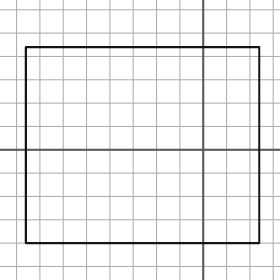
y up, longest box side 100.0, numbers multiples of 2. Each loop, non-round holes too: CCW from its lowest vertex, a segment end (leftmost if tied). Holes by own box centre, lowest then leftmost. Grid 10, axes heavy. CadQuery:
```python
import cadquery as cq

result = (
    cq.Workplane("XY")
    .moveTo(-76.0, -40.0)
    .lineTo(24.0, -40.0)
    .lineTo(24.0, 44.0)
    .lineTo(-76.0, 44.0)
    .close()
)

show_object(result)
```